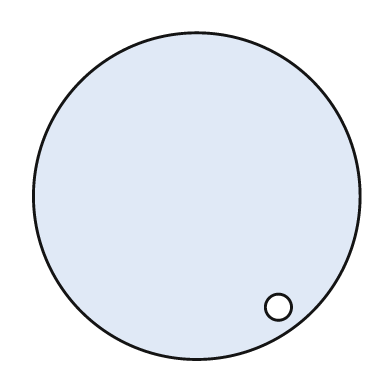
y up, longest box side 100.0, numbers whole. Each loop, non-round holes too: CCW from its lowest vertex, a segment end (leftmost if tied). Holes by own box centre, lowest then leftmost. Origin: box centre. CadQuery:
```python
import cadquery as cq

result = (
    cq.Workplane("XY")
    .moveTo(0.0, 0.0)
    .circle(50.0)
    .moveTo(25.0, -34.0)
    .circle(4.0)
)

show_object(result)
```